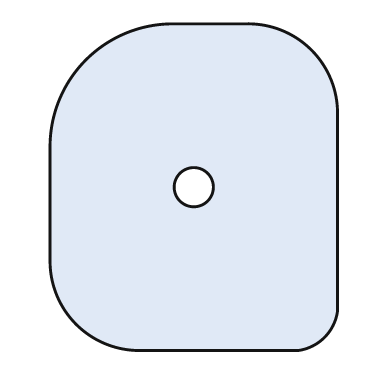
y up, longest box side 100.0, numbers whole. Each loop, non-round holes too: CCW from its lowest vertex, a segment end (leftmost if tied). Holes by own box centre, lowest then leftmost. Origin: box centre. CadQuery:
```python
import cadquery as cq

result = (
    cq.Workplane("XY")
    .moveTo(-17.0, -50.0)
    .lineTo(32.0, -50.0)
    .threePointArc((40.0, -46.0), (44.0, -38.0))
    .lineTo(44.0, 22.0)
    .threePointArc((36.0, 42.0), (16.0, 50.0))
    .lineTo(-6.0, 50.0)
    .threePointArc((-33.0, 39.0), (-44.0, 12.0))
    .lineTo(-44.0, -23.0)
    .threePointArc((-36.0, -42.0), (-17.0, -50.0))
    .close()
    .moveTo(0.0, 0.0)
    .circle(6.0)
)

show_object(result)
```